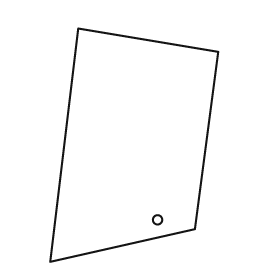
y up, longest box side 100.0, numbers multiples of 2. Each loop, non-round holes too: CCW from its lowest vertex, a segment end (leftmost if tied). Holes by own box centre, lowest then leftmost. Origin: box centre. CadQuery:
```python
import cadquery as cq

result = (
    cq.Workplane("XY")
    .moveTo(-36.0, -50.0)
    .lineTo(26.0, -36.0)
    .lineTo(36.0, 40.0)
    .lineTo(-24.0, 50.0)
    .close()
    .moveTo(10.0, -32.0)
    .circle(2.0)
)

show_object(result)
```